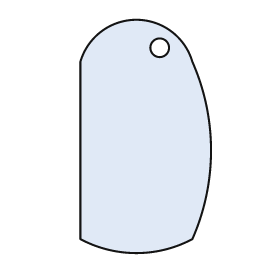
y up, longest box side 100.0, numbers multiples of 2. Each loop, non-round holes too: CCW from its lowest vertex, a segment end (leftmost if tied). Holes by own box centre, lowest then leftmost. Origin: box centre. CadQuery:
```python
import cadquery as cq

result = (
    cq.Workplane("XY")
    .moveTo(-28.0, -44.0)
    .threePointArc((-4.0, -50.0), (20.0, -44.0))
    .threePointArc((28.0, -6.0), (20.0, 32.0))
    .threePointArc((-4.0, 50.0), (-28.0, 32.0))
    .close()
    .moveTo(6.0, 38.0)
    .circle(4.0)
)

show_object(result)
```